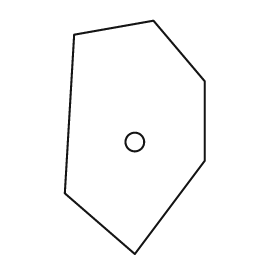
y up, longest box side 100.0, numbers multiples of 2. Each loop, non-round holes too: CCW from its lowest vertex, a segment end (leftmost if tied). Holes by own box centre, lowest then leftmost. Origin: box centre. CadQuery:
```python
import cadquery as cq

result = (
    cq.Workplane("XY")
    .moveTo(0.0, -50.0)
    .lineTo(30.0, -10.0)
    .lineTo(30.0, 24.0)
    .lineTo(8.0, 50.0)
    .lineTo(-26.0, 44.0)
    .lineTo(-30.0, -24.0)
    .close()
    .moveTo(0.0, -2.0)
    .circle(4.0)
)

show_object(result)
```